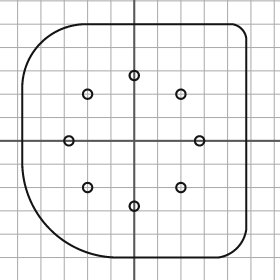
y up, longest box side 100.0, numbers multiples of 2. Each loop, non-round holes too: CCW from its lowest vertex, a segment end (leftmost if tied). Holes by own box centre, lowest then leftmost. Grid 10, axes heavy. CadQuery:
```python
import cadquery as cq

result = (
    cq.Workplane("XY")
    .moveTo(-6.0, -50.0)
    .lineTo(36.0, -50.0)
    .threePointArc((44.0, -46.0), (48.0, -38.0))
    .lineTo(48.0, 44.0)
    .threePointArc((46.0, 48.0), (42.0, 50.0))
    .lineTo(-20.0, 50.0)
    .threePointArc((-40.0, 42.0), (-48.0, 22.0))
    .lineTo(-48.0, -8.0)
    .threePointArc((-36.0, -38.0), (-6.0, -50.0))
    .close()
    .moveTo(0.0, -28.0)
    .circle(2.0)
    .moveTo(-20.0, -20.0)
    .circle(2.0)
    .moveTo(20.0, -20.0)
    .circle(2.0)
    .moveTo(-28.0, 0.0)
    .circle(2.0)
    .moveTo(28.0, 0.0)
    .circle(2.0)
    .moveTo(-20.0, 20.0)
    .circle(2.0)
    .moveTo(20.0, 20.0)
    .circle(2.0)
    .moveTo(0.0, 28.0)
    .circle(2.0)
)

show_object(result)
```